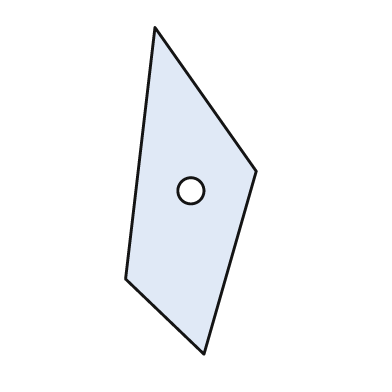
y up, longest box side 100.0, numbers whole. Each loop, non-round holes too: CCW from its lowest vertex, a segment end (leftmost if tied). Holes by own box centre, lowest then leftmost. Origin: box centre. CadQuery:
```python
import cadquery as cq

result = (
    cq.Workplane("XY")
    .moveTo(4.0, -50.0)
    .lineTo(20.0, 6.0)
    .lineTo(-11.0, 50.0)
    .lineTo(-20.0, -27.0)
    .close()
    .moveTo(0.0, 0.0)
    .circle(4.0)
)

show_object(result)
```